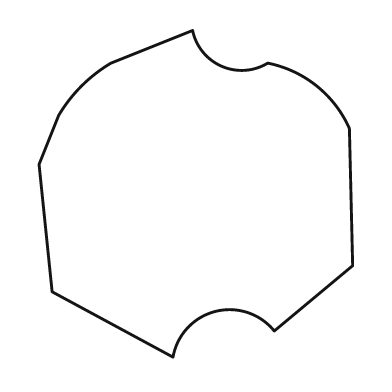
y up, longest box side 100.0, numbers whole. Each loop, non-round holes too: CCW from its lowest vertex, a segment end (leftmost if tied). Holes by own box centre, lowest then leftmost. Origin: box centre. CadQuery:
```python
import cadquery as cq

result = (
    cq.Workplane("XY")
    .moveTo(-7.0, -50.0)
    .threePointArc((6.0, -36.0), (24.0, -42.0))
    .lineTo(48.0, -22.0)
    .lineTo(47.0, 20.0)
    .threePointArc((37.0, 33.0), (22.0, 40.0))
    .threePointArc((8.0, 39.0), (-1.0, 50.0))
    .lineTo(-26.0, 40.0)
    .threePointArc((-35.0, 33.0), (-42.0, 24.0))
    .lineTo(-48.0, 9.0)
    .lineTo(-44.0, -30.0)
    .close()
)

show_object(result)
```